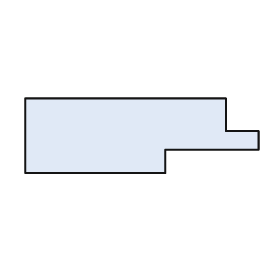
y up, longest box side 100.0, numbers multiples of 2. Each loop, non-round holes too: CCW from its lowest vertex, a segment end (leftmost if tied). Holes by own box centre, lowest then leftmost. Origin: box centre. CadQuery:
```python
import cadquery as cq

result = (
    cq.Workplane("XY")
    .moveTo(-50.0, -16.0)
    .lineTo(10.0, -16.0)
    .lineTo(10.0, -6.0)
    .lineTo(50.0, -6.0)
    .lineTo(50.0, 2.0)
    .lineTo(36.0, 2.0)
    .lineTo(36.0, 16.0)
    .lineTo(-50.0, 16.0)
    .close()
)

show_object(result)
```